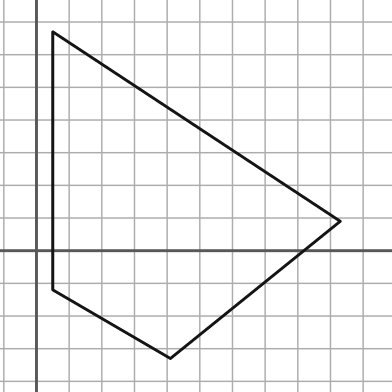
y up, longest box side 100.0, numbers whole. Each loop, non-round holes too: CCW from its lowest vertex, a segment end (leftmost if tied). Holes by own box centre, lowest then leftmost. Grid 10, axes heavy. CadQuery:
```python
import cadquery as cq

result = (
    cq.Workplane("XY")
    .moveTo(41.0, -33.0)
    .lineTo(93.0, 9.0)
    .lineTo(5.0, 67.0)
    .lineTo(5.0, -12.0)
    .close()
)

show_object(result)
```